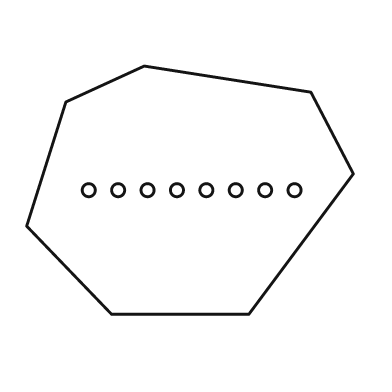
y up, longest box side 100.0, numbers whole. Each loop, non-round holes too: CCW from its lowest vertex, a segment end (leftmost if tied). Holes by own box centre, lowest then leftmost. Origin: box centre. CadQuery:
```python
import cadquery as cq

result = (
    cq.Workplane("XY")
    .moveTo(-24.0, -38.0)
    .lineTo(18.0, -38.0)
    .lineTo(50.0, 5.0)
    .lineTo(37.0, 30.0)
    .lineTo(-14.0, 38.0)
    .lineTo(-38.0, 27.0)
    .lineTo(-50.0, -11.0)
    .close()
    .moveTo(-31.0, 0.0)
    .circle(2.0)
    .moveTo(-22.0, 0.0)
    .circle(2.0)
    .moveTo(-13.0, 0.0)
    .circle(2.0)
    .moveTo(-4.0, 0.0)
    .circle(2.0)
    .moveTo(5.0, 0.0)
    .circle(2.0)
    .moveTo(14.0, 0.0)
    .circle(2.0)
    .moveTo(23.0, 0.0)
    .circle(2.0)
    .moveTo(32.0, 0.0)
    .circle(2.0)
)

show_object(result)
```